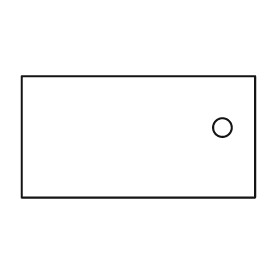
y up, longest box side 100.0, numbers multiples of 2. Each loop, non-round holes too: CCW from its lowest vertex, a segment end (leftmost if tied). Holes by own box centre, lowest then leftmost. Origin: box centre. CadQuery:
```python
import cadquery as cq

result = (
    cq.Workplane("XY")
    .moveTo(-50.0, -26.0)
    .lineTo(50.0, -26.0)
    .lineTo(50.0, 26.0)
    .lineTo(-50.0, 26.0)
    .close()
    .moveTo(36.0, 4.0)
    .circle(4.0)
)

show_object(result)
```